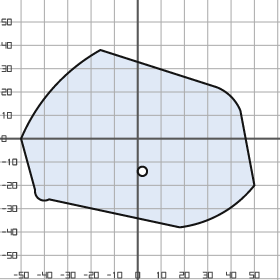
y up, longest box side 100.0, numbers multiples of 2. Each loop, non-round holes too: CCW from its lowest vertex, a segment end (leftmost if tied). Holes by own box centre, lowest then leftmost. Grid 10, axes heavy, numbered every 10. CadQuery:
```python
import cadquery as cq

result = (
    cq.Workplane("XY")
    .moveTo(18.0, -38.0)
    .threePointArc((36.0, -32.0), (50.0, -20.0))
    .lineTo(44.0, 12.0)
    .threePointArc((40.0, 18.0), (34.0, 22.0))
    .lineTo(-16.0, 38.0)
    .threePointArc((-36.0, 22.0), (-50.0, 0.0))
    .lineTo(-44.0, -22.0)
    .threePointArc((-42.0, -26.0), (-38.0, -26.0))
    .close()
    .moveTo(2.0, -14.0)
    .circle(2.0)
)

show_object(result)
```